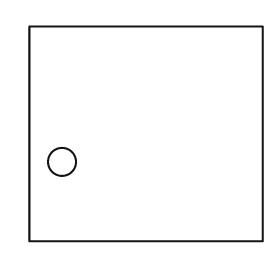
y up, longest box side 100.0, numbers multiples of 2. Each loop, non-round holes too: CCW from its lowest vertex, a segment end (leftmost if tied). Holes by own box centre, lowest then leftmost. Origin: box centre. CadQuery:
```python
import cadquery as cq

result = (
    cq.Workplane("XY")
    .moveTo(-50.0, -46.0)
    .lineTo(50.0, -46.0)
    .lineTo(50.0, 46.0)
    .lineTo(-50.0, 46.0)
    .close()
    .moveTo(-36.0, -12.0)
    .circle(6.0)
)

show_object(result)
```